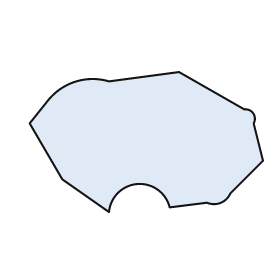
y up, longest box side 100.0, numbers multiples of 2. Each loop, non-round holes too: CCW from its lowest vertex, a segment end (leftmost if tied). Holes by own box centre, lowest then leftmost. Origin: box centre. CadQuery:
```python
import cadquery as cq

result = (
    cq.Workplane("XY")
    .moveTo(-16.0, -30.0)
    .threePointArc((-4.0, -18.0), (10.0, -28.0))
    .lineTo(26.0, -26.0)
    .threePointArc((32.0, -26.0), (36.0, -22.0))
    .lineTo(50.0, -8.0)
    .lineTo(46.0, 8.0)
    .threePointArc((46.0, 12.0), (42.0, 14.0))
    .lineTo(14.0, 30.0)
    .lineTo(-16.0, 26.0)
    .threePointArc((-30.0, 26.0), (-42.0, 18.0))
    .lineTo(-50.0, 8.0)
    .lineTo(-36.0, -16.0)
    .close()
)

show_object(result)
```